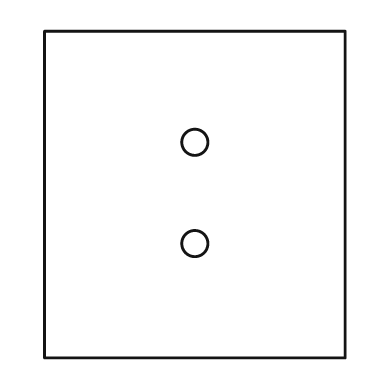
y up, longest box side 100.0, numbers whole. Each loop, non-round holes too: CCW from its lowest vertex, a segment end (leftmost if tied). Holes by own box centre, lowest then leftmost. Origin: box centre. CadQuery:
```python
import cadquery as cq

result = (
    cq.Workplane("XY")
    .moveTo(-46.0, -50.0)
    .lineTo(46.0, -50.0)
    .lineTo(46.0, 50.0)
    .lineTo(-46.0, 50.0)
    .close()
    .moveTo(0.0, -15.0)
    .circle(4.0)
    .moveTo(0.0, 16.0)
    .circle(4.0)
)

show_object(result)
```